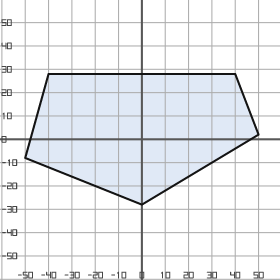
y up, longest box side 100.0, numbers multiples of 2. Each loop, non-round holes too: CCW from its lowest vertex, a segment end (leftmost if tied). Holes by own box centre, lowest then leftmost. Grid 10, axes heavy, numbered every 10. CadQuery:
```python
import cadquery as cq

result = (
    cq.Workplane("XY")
    .moveTo(0.0, -28.0)
    .lineTo(50.0, 2.0)
    .lineTo(40.0, 28.0)
    .lineTo(-40.0, 28.0)
    .lineTo(-50.0, -8.0)
    .close()
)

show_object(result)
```